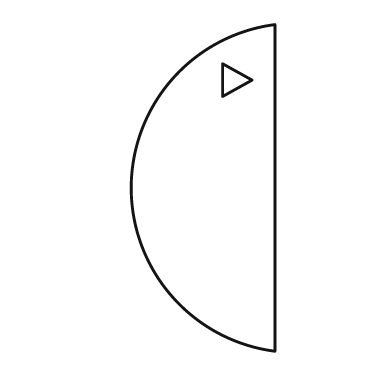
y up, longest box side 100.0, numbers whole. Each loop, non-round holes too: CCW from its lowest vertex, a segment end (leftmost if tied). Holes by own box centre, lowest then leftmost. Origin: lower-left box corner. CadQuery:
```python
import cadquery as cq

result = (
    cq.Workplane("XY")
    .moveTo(44.0, 0.0)
    .lineTo(44.0, 100.0)
    .threePointArc((0.0, 50.0), (44.0, 0.0))
    .close()
    .moveTo(28.0, 78.0)
    .lineTo(37.0, 83.0)
    .lineTo(28.0, 88.0)
    .close()
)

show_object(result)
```